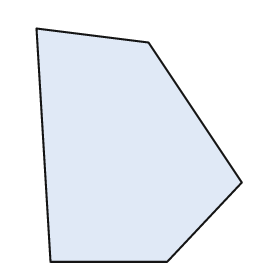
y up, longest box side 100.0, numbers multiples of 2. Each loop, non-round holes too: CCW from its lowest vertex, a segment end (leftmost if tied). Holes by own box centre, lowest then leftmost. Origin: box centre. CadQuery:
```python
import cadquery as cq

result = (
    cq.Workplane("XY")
    .moveTo(-38.0, -50.0)
    .lineTo(12.0, -50.0)
    .lineTo(44.0, -16.0)
    .lineTo(4.0, 44.0)
    .lineTo(-44.0, 50.0)
    .close()
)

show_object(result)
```